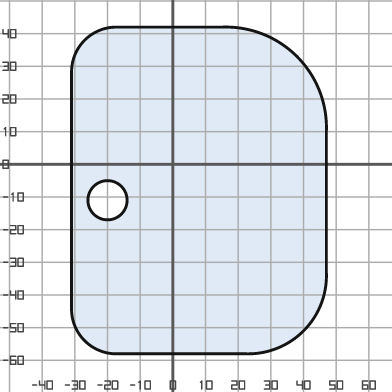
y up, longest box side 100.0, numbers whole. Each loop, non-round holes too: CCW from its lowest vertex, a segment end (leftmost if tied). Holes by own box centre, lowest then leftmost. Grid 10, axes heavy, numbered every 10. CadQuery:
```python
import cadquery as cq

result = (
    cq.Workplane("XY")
    .moveTo(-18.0, -58.0)
    .lineTo(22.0, -58.0)
    .threePointArc((40.0, -51.0), (47.0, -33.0))
    .lineTo(47.0, 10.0)
    .threePointArc((38.0, 33.0), (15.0, 42.0))
    .lineTo(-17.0, 42.0)
    .threePointArc((-27.0, 38.0), (-31.0, 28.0))
    .lineTo(-31.0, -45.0)
    .threePointArc((-27.0, -54.0), (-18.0, -58.0))
    .close()
    .moveTo(-20.0, -11.0)
    .circle(6.0)
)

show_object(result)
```